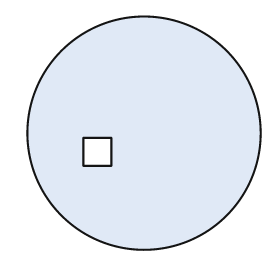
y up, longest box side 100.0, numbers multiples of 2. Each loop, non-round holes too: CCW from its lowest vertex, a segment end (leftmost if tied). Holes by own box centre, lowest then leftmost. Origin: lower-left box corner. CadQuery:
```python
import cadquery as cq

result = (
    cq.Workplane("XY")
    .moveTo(50.0, 50.0)
    .circle(50.0)
    .moveTo(24.0, 36.0)
    .lineTo(36.0, 36.0)
    .lineTo(36.0, 48.0)
    .lineTo(24.0, 48.0)
    .close()
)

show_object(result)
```